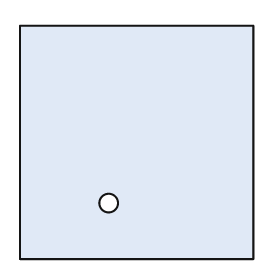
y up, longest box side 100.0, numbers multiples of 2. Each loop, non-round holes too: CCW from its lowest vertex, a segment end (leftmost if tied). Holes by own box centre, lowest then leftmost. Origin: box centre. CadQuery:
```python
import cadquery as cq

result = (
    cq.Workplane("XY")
    .moveTo(-50.0, -50.0)
    .lineTo(50.0, -50.0)
    .lineTo(50.0, 50.0)
    .lineTo(-50.0, 50.0)
    .close()
    .moveTo(-12.0, -26.0)
    .circle(4.0)
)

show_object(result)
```